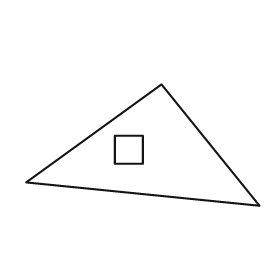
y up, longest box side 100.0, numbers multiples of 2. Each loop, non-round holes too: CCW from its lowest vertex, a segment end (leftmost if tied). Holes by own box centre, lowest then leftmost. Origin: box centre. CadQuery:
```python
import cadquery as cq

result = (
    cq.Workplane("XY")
    .moveTo(50.0, -26.0)
    .lineTo(8.0, 26.0)
    .lineTo(-50.0, -16.0)
    .close()
    .moveTo(-12.0, -8.0)
    .lineTo(0.0, -8.0)
    .lineTo(0.0, 4.0)
    .lineTo(-12.0, 4.0)
    .close()
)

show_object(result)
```